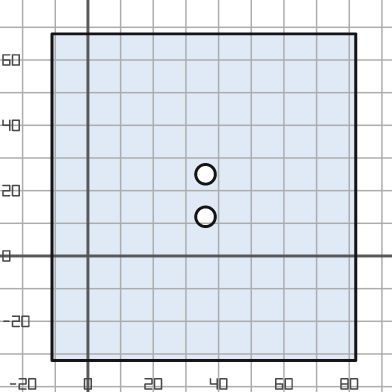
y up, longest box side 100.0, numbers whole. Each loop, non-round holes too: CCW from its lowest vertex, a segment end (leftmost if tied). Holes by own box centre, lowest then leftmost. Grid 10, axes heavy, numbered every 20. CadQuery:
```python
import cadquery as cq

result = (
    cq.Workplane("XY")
    .moveTo(-11.0, -32.0)
    .lineTo(82.0, -32.0)
    .lineTo(82.0, 68.0)
    .lineTo(-11.0, 68.0)
    .close()
    .moveTo(36.0, 12.0)
    .circle(3.0)
    .moveTo(36.0, 25.0)
    .circle(3.0)
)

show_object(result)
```